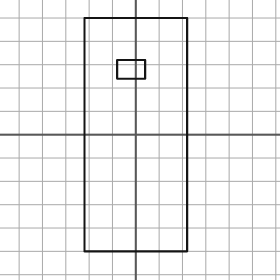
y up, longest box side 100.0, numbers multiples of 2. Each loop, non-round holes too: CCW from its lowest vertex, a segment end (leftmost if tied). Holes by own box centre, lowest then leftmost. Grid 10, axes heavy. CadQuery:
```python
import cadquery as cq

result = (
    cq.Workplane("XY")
    .moveTo(-22.0, -50.0)
    .lineTo(22.0, -50.0)
    .lineTo(22.0, 50.0)
    .lineTo(-22.0, 50.0)
    .close()
    .moveTo(-8.0, 24.0)
    .lineTo(4.0, 24.0)
    .lineTo(4.0, 32.0)
    .lineTo(-8.0, 32.0)
    .close()
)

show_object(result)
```